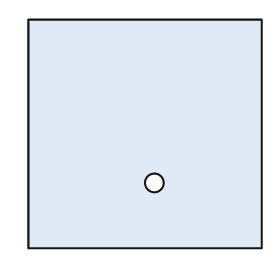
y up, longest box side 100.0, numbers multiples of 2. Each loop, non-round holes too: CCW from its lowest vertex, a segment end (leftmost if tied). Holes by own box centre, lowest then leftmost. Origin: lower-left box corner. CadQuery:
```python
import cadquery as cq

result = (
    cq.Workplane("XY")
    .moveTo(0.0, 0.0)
    .lineTo(100.0, 0.0)
    .lineTo(100.0, 98.0)
    .lineTo(0.0, 98.0)
    .close()
    .moveTo(54.0, 28.0)
    .circle(4.0)
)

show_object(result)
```